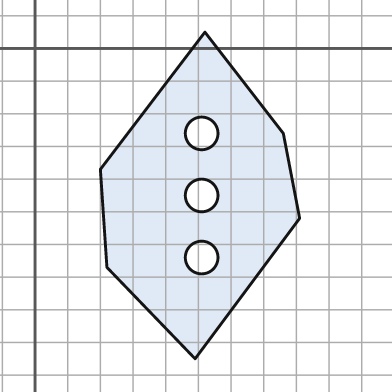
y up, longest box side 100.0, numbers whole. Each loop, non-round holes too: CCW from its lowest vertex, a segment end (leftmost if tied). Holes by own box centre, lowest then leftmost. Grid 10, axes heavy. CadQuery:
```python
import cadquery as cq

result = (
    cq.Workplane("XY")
    .moveTo(49.0, -95.0)
    .lineTo(81.0, -52.0)
    .lineTo(76.0, -26.0)
    .lineTo(52.0, 5.0)
    .lineTo(20.0, -37.0)
    .lineTo(22.0, -67.0)
    .close()
    .moveTo(51.0, -64.0)
    .circle(5.0)
    .moveTo(51.0, -45.0)
    .circle(5.0)
    .moveTo(51.0, -26.0)
    .circle(5.0)
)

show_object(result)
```